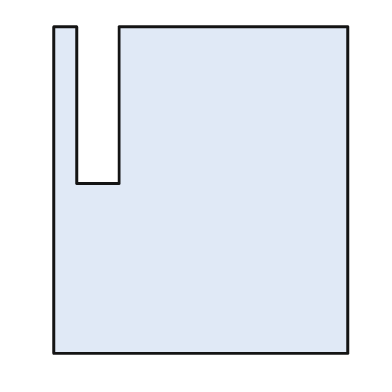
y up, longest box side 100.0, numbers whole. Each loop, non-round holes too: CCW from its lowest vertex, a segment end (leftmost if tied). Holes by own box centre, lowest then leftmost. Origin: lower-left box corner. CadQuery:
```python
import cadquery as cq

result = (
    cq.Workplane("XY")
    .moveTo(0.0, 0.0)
    .lineTo(90.0, 0.0)
    .lineTo(90.0, 100.0)
    .lineTo(20.0, 100.0)
    .lineTo(20.0, 52.0)
    .lineTo(7.0, 52.0)
    .lineTo(7.0, 100.0)
    .lineTo(0.0, 100.0)
    .close()
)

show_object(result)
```